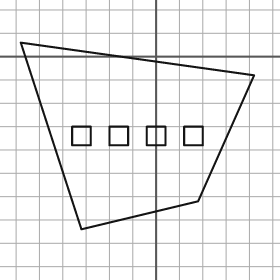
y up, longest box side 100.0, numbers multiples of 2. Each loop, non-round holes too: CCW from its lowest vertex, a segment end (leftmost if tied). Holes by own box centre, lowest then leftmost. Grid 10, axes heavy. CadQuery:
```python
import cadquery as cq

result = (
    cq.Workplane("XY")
    .moveTo(-32.0, -74.0)
    .lineTo(18.0, -62.0)
    .lineTo(42.0, -8.0)
    .lineTo(-58.0, 6.0)
    .close()
    .moveTo(-36.0, -38.0)
    .lineTo(-28.0, -38.0)
    .lineTo(-28.0, -30.0)
    .lineTo(-36.0, -30.0)
    .close()
    .moveTo(-20.0, -38.0)
    .lineTo(-12.0, -38.0)
    .lineTo(-12.0, -30.0)
    .lineTo(-20.0, -30.0)
    .close()
    .moveTo(-4.0, -38.0)
    .lineTo(4.0, -38.0)
    .lineTo(4.0, -30.0)
    .lineTo(-4.0, -30.0)
    .close()
    .moveTo(12.0, -38.0)
    .lineTo(20.0, -38.0)
    .lineTo(20.0, -30.0)
    .lineTo(12.0, -30.0)
    .close()
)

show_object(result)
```